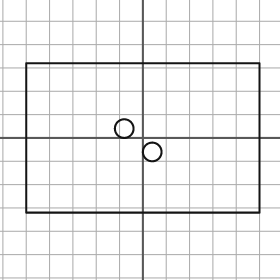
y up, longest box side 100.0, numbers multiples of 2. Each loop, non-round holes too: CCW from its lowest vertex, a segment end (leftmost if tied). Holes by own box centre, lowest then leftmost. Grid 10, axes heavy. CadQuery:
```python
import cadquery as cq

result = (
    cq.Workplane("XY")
    .moveTo(-50.0, -32.0)
    .lineTo(50.0, -32.0)
    .lineTo(50.0, 32.0)
    .lineTo(-50.0, 32.0)
    .close()
    .moveTo(4.0, -6.0)
    .circle(4.0)
    .moveTo(-8.0, 4.0)
    .circle(4.0)
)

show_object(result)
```